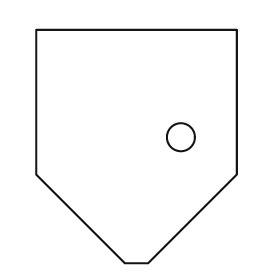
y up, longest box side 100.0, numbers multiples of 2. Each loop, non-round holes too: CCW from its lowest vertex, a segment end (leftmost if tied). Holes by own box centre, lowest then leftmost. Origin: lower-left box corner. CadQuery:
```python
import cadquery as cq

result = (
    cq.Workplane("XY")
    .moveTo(38.0, 0.0)
    .lineTo(48.0, 0.0)
    .lineTo(86.0, 38.0)
    .lineTo(86.0, 100.0)
    .lineTo(0.0, 100.0)
    .lineTo(0.0, 38.0)
    .close()
    .moveTo(62.0, 54.0)
    .circle(6.0)
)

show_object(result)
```